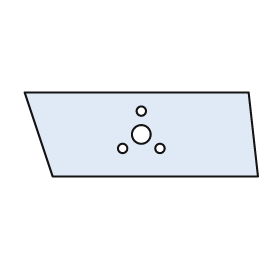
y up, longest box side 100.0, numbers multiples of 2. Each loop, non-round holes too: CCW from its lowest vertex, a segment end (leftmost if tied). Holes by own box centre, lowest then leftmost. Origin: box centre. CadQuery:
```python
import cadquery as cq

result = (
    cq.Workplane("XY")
    .moveTo(-38.0, -18.0)
    .lineTo(50.0, -18.0)
    .lineTo(46.0, 18.0)
    .lineTo(-50.0, 18.0)
    .close()
    .moveTo(-8.0, -6.0)
    .circle(2.0)
    .moveTo(8.0, -6.0)
    .circle(2.0)
    .moveTo(0.0, 0.0)
    .circle(4.0)
    .moveTo(0.0, 10.0)
    .circle(2.0)
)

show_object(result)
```